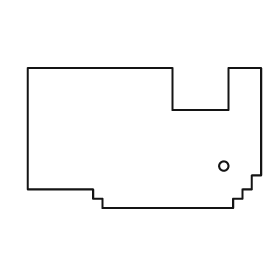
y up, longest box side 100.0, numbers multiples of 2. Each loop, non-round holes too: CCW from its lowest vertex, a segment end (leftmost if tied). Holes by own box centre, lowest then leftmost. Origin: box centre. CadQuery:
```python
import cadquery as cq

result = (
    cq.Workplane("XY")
    .moveTo(-18.0, -30.0)
    .lineTo(38.0, -30.0)
    .lineTo(38.0, -26.0)
    .lineTo(42.0, -26.0)
    .lineTo(42.0, -22.0)
    .lineTo(46.0, -22.0)
    .lineTo(46.0, -16.0)
    .lineTo(50.0, -16.0)
    .lineTo(50.0, 30.0)
    .lineTo(36.0, 30.0)
    .lineTo(36.0, 12.0)
    .lineTo(12.0, 12.0)
    .lineTo(12.0, 30.0)
    .lineTo(-50.0, 30.0)
    .lineTo(-50.0, -22.0)
    .lineTo(-22.0, -22.0)
    .lineTo(-22.0, -26.0)
    .lineTo(-18.0, -26.0)
    .close()
    .moveTo(34.0, -12.0)
    .circle(2.0)
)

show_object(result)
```